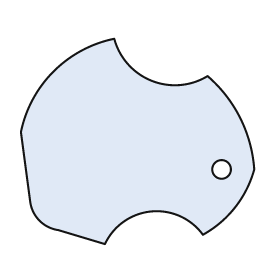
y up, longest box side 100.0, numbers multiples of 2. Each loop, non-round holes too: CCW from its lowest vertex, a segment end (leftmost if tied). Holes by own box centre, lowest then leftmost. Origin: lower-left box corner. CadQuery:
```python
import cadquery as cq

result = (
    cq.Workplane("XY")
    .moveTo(36.0, 0.0)
    .threePointArc((56.0, 14.0), (78.0, 4.0))
    .threePointArc((92.0, 16.0), (100.0, 32.0))
    .threePointArc((94.0, 54.0), (80.0, 72.0))
    .threePointArc((56.0, 70.0), (40.0, 88.0))
    .threePointArc((14.0, 74.0), (0.0, 48.0))
    .lineTo(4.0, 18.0)
    .threePointArc((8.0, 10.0), (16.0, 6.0))
    .close()
    .moveTo(86.0, 32.0)
    .circle(4.0)
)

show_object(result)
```